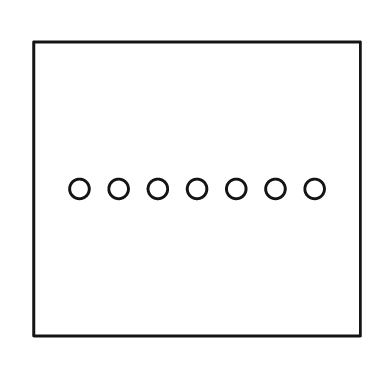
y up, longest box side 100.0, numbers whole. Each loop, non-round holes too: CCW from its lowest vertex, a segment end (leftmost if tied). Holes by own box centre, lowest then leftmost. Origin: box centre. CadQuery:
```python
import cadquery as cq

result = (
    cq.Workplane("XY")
    .moveTo(-50.0, -45.0)
    .lineTo(50.0, -45.0)
    .lineTo(50.0, 45.0)
    .lineTo(-50.0, 45.0)
    .close()
    .moveTo(-36.0, 0.0)
    .circle(3.0)
    .moveTo(-24.0, 0.0)
    .circle(3.0)
    .moveTo(-12.0, 0.0)
    .circle(3.0)
    .moveTo(0.0, 0.0)
    .circle(3.0)
    .moveTo(12.0, 0.0)
    .circle(3.0)
    .moveTo(24.0, 0.0)
    .circle(3.0)
    .moveTo(36.0, 0.0)
    .circle(3.0)
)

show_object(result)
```